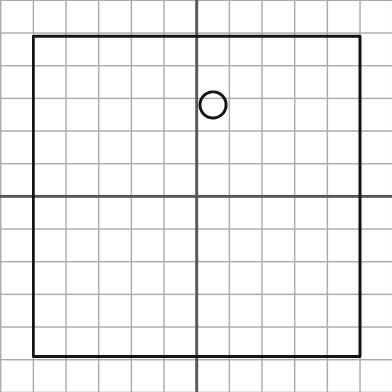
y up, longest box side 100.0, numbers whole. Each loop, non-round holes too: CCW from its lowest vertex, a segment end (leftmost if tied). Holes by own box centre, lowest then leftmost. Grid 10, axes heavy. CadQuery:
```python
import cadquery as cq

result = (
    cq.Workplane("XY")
    .moveTo(-50.0, -49.0)
    .lineTo(50.0, -49.0)
    .lineTo(50.0, 49.0)
    .lineTo(-50.0, 49.0)
    .close()
    .moveTo(5.0, 28.0)
    .circle(4.0)
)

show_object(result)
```